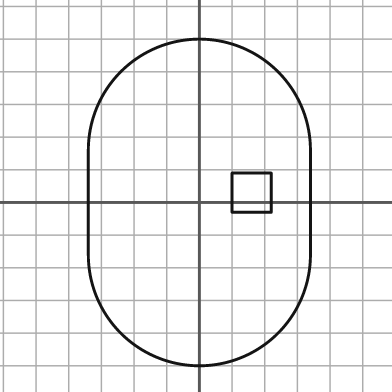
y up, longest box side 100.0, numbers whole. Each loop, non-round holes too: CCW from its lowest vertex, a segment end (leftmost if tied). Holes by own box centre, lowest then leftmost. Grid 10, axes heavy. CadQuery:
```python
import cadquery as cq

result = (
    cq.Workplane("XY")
    .moveTo(-34.0, -16.0)
    .threePointArc((0.0, -50.0), (34.0, -16.0))
    .lineTo(34.0, 16.0)
    .threePointArc((0.0, 50.0), (-34.0, 16.0))
    .close()
    .moveTo(10.0, -3.0)
    .lineTo(22.0, -3.0)
    .lineTo(22.0, 9.0)
    .lineTo(10.0, 9.0)
    .close()
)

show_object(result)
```